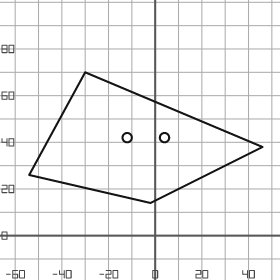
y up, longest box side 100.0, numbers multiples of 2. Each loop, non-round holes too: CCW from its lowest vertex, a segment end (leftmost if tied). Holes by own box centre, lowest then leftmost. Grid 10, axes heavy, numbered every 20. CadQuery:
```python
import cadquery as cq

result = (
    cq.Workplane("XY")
    .moveTo(-2.0, 14.0)
    .lineTo(46.0, 38.0)
    .lineTo(-30.0, 70.0)
    .lineTo(-54.0, 26.0)
    .close()
    .moveTo(-12.0, 42.0)
    .circle(2.0)
    .moveTo(4.0, 42.0)
    .circle(2.0)
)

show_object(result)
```